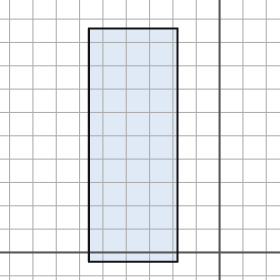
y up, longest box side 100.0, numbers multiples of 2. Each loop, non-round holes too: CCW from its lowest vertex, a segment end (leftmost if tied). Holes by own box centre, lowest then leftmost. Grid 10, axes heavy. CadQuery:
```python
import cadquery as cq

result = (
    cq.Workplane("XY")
    .moveTo(-56.0, -4.0)
    .lineTo(-18.0, -4.0)
    .lineTo(-18.0, 96.0)
    .lineTo(-56.0, 96.0)
    .close()
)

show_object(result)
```